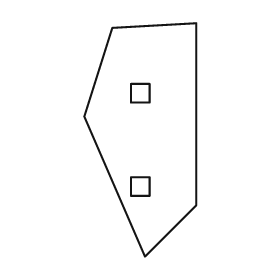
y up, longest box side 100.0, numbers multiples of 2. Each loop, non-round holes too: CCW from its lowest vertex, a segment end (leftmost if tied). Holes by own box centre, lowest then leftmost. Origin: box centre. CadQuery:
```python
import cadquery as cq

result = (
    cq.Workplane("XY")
    .moveTo(2.0, -50.0)
    .lineTo(24.0, -28.0)
    .lineTo(24.0, 50.0)
    .lineTo(-12.0, 48.0)
    .lineTo(-24.0, 10.0)
    .close()
    .moveTo(-4.0, -24.0)
    .lineTo(4.0, -24.0)
    .lineTo(4.0, -16.0)
    .lineTo(-4.0, -16.0)
    .close()
    .moveTo(-4.0, 16.0)
    .lineTo(4.0, 16.0)
    .lineTo(4.0, 24.0)
    .lineTo(-4.0, 24.0)
    .close()
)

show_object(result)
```